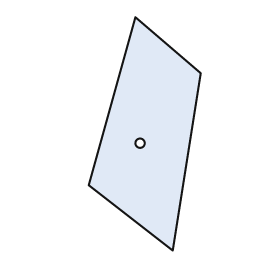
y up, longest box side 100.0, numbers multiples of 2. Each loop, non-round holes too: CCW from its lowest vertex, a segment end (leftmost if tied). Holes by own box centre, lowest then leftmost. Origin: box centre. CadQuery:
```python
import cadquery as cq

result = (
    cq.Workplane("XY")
    .moveTo(12.0, -50.0)
    .lineTo(24.0, 26.0)
    .lineTo(-4.0, 50.0)
    .lineTo(-24.0, -22.0)
    .close()
    .moveTo(-2.0, -4.0)
    .circle(2.0)
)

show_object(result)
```